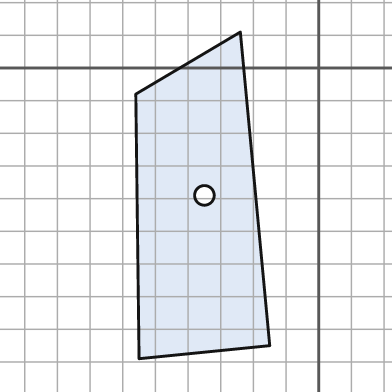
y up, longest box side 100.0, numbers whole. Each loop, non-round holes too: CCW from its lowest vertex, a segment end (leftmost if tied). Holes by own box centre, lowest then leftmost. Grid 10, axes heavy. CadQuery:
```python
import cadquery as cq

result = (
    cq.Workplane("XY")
    .moveTo(-55.0, -89.0)
    .lineTo(-15.0, -85.0)
    .lineTo(-24.0, 11.0)
    .lineTo(-56.0, -8.0)
    .close()
    .moveTo(-35.0, -39.0)
    .circle(3.0)
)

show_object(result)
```